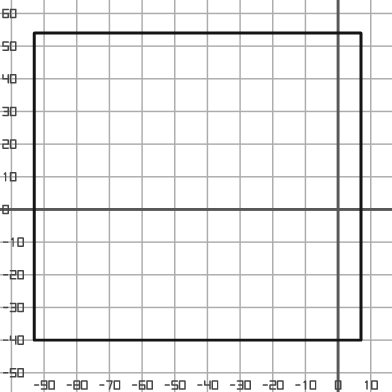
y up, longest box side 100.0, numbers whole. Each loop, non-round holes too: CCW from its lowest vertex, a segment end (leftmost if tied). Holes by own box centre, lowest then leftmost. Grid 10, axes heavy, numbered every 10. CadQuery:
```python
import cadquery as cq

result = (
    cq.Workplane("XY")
    .moveTo(-93.0, -40.0)
    .lineTo(7.0, -40.0)
    .lineTo(7.0, 54.0)
    .lineTo(-93.0, 54.0)
    .close()
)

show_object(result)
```